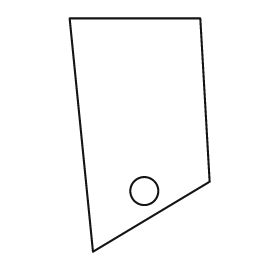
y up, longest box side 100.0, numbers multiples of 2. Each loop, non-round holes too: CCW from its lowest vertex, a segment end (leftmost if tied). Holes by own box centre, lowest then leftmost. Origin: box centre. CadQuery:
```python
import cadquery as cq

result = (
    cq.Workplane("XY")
    .moveTo(-20.0, -50.0)
    .lineTo(30.0, -20.0)
    .lineTo(26.0, 50.0)
    .lineTo(-30.0, 50.0)
    .close()
    .moveTo(2.0, -24.0)
    .circle(6.0)
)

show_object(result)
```